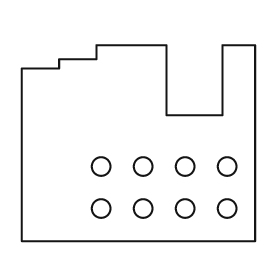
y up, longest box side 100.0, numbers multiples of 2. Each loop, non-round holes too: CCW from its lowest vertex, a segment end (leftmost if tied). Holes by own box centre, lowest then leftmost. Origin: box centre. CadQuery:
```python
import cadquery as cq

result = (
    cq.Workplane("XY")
    .moveTo(-50.0, -42.0)
    .lineTo(50.0, -42.0)
    .lineTo(50.0, 42.0)
    .lineTo(36.0, 42.0)
    .lineTo(36.0, 12.0)
    .lineTo(12.0, 12.0)
    .lineTo(12.0, 42.0)
    .lineTo(-18.0, 42.0)
    .lineTo(-18.0, 36.0)
    .lineTo(-34.0, 36.0)
    .lineTo(-34.0, 32.0)
    .lineTo(-50.0, 32.0)
    .close()
    .moveTo(-16.0, -28.0)
    .circle(4.0)
    .moveTo(2.0, -28.0)
    .circle(4.0)
    .moveTo(20.0, -28.0)
    .circle(4.0)
    .moveTo(38.0, -28.0)
    .circle(4.0)
    .moveTo(-16.0, -10.0)
    .circle(4.0)
    .moveTo(2.0, -10.0)
    .circle(4.0)
    .moveTo(20.0, -10.0)
    .circle(4.0)
    .moveTo(38.0, -10.0)
    .circle(4.0)
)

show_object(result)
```